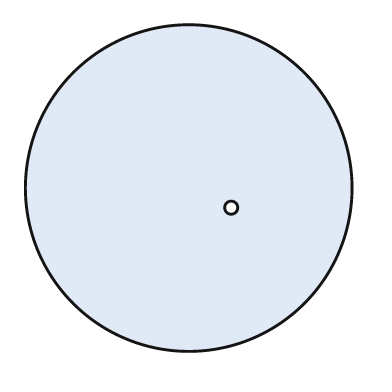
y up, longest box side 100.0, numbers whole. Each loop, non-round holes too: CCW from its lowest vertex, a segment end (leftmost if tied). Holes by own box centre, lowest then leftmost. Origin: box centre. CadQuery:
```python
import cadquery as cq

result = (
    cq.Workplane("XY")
    .moveTo(0.0, 0.0)
    .circle(50.0)
    .moveTo(13.0, -6.0)
    .circle(2.0)
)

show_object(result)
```